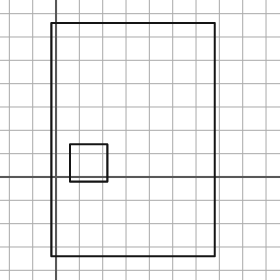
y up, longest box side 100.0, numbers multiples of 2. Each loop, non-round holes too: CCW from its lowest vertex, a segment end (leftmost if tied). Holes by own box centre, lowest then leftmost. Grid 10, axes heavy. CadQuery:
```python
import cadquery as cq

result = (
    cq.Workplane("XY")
    .moveTo(-2.0, -34.0)
    .lineTo(68.0, -34.0)
    .lineTo(68.0, 66.0)
    .lineTo(-2.0, 66.0)
    .close()
    .moveTo(6.0, -2.0)
    .lineTo(22.0, -2.0)
    .lineTo(22.0, 14.0)
    .lineTo(6.0, 14.0)
    .close()
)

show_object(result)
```